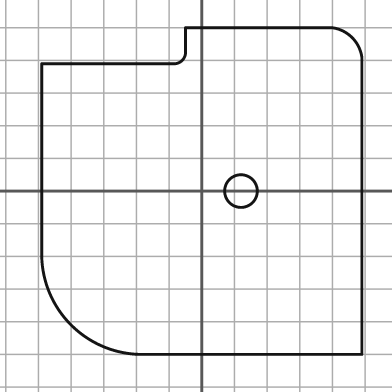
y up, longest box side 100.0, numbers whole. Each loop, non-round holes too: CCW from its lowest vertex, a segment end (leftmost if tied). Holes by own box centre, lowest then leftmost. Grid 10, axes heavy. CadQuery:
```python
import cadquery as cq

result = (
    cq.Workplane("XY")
    .moveTo(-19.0, -50.0)
    .lineTo(49.0, -50.0)
    .lineTo(49.0, 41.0)
    .threePointArc((46.0, 47.0), (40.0, 50.0))
    .lineTo(-5.0, 50.0)
    .lineTo(-5.0, 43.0)
    .threePointArc((-6.0, 40.0), (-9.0, 39.0))
    .lineTo(-49.0, 39.0)
    .lineTo(-49.0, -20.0)
    .threePointArc((-40.0, -41.0), (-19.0, -50.0))
    .close()
    .moveTo(12.0, 0.0)
    .circle(5.0)
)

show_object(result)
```